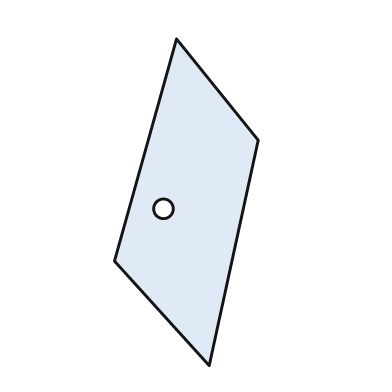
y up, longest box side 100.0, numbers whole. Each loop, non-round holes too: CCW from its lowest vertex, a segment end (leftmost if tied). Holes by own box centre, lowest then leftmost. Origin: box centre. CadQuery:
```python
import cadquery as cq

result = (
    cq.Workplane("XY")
    .moveTo(7.0, -50.0)
    .lineTo(22.0, 19.0)
    .lineTo(-3.0, 50.0)
    .lineTo(-22.0, -18.0)
    .close()
    .moveTo(-7.0, -2.0)
    .circle(3.0)
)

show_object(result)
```